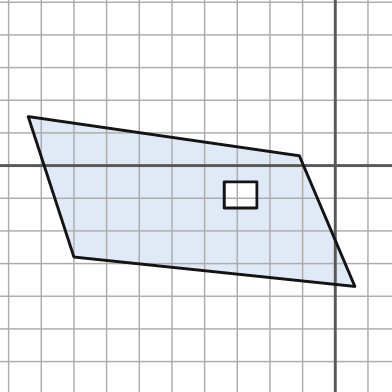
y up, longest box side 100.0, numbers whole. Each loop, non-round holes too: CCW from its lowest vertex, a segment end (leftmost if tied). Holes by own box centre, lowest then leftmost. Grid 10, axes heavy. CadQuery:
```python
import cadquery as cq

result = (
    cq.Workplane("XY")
    .moveTo(6.0, -37.0)
    .lineTo(-11.0, 3.0)
    .lineTo(-94.0, 15.0)
    .lineTo(-80.0, -28.0)
    .close()
    .moveTo(-34.0, -13.0)
    .lineTo(-24.0, -13.0)
    .lineTo(-24.0, -5.0)
    .lineTo(-34.0, -5.0)
    .close()
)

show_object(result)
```